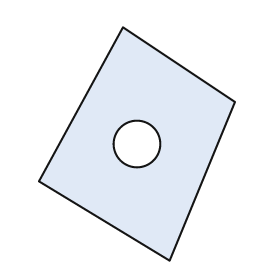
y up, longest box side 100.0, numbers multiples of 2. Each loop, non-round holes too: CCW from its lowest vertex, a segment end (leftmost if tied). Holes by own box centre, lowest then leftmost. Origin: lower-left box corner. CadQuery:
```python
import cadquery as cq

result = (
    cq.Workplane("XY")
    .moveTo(56.0, 0.0)
    .lineTo(84.0, 68.0)
    .lineTo(36.0, 100.0)
    .lineTo(0.0, 34.0)
    .close()
    .moveTo(42.0, 50.0)
    .circle(10.0)
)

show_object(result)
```